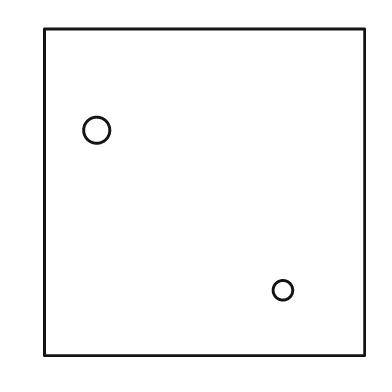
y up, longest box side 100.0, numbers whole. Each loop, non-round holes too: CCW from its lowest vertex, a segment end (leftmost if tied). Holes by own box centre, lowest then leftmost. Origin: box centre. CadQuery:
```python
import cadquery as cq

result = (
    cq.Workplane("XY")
    .moveTo(-49.0, -50.0)
    .lineTo(49.0, -50.0)
    .lineTo(49.0, 50.0)
    .lineTo(-49.0, 50.0)
    .close()
    .moveTo(24.0, -30.0)
    .circle(3.0)
    .moveTo(-33.0, 19.0)
    .circle(4.0)
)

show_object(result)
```